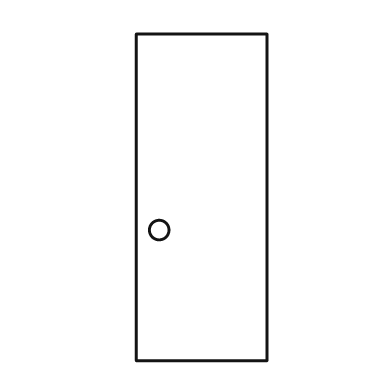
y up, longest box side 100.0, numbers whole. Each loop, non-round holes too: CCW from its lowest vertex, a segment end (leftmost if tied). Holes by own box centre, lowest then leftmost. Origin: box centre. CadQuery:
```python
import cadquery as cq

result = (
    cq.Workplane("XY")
    .moveTo(-20.0, -50.0)
    .lineTo(20.0, -50.0)
    .lineTo(20.0, 50.0)
    .lineTo(-20.0, 50.0)
    .close()
    .moveTo(-13.0, -10.0)
    .circle(3.0)
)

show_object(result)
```